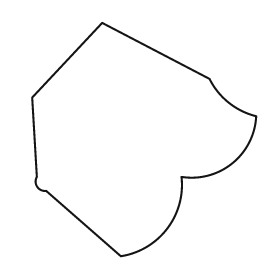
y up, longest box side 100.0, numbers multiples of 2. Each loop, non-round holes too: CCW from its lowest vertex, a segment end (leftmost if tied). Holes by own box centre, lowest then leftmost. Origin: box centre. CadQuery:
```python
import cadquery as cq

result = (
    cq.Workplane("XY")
    .moveTo(-10.0, -50.0)
    .threePointArc((10.0, -38.0), (16.0, -16.0))
    .threePointArc((38.0, -10.0), (48.0, 10.0))
    .threePointArc((36.0, 16.0), (28.0, 26.0))
    .lineTo(-18.0, 50.0)
    .lineTo(-48.0, 18.0)
    .lineTo(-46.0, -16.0)
    .threePointArc((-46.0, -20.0), (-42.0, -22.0))
    .close()
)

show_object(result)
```